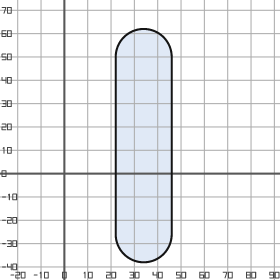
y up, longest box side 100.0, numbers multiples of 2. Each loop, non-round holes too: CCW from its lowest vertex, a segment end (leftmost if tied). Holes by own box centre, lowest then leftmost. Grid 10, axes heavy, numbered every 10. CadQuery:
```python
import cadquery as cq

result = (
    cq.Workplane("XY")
    .moveTo(22.0, -26.0)
    .threePointArc((34.0, -38.0), (46.0, -26.0))
    .lineTo(46.0, 50.0)
    .threePointArc((34.0, 62.0), (22.0, 50.0))
    .close()
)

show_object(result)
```